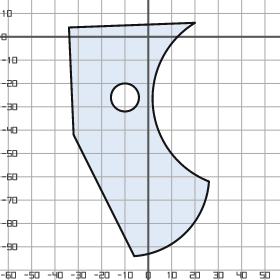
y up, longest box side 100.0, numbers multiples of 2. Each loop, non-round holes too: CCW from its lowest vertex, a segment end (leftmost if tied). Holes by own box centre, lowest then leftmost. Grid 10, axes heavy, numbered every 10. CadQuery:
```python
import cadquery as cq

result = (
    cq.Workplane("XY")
    .moveTo(-6.0, -94.0)
    .threePointArc((16.0, -84.0), (26.0, -62.0))
    .threePointArc((2.0, -30.0), (20.0, 6.0))
    .lineTo(-34.0, 4.0)
    .lineTo(-32.0, -42.0)
    .close()
    .moveTo(-10.0, -26.0)
    .circle(6.0)
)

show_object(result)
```